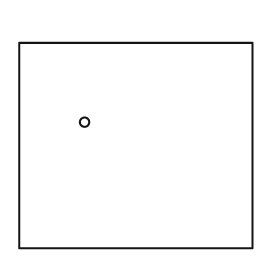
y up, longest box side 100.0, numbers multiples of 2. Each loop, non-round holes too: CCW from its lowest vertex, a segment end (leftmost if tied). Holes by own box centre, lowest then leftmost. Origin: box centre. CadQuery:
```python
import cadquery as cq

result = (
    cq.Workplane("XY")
    .moveTo(-50.0, -44.0)
    .lineTo(50.0, -44.0)
    .lineTo(50.0, 44.0)
    .lineTo(-50.0, 44.0)
    .close()
    .moveTo(-22.0, 10.0)
    .circle(2.0)
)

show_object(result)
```